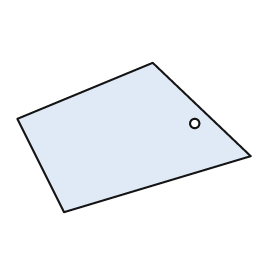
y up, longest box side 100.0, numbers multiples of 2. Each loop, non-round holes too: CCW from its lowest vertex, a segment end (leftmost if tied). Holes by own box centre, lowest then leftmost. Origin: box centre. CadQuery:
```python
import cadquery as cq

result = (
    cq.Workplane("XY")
    .moveTo(-30.0, -32.0)
    .lineTo(50.0, -8.0)
    .lineTo(8.0, 32.0)
    .lineTo(-50.0, 8.0)
    .close()
    .moveTo(26.0, 6.0)
    .circle(2.0)
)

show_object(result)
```